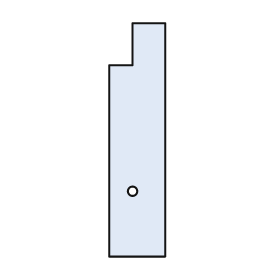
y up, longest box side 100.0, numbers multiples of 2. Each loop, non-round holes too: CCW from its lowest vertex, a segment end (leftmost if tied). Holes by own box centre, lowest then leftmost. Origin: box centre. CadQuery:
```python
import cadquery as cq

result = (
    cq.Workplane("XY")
    .moveTo(-12.0, -50.0)
    .lineTo(12.0, -50.0)
    .lineTo(12.0, 50.0)
    .lineTo(-2.0, 50.0)
    .lineTo(-2.0, 32.0)
    .lineTo(-12.0, 32.0)
    .close()
    .moveTo(-2.0, -22.0)
    .circle(2.0)
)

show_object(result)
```